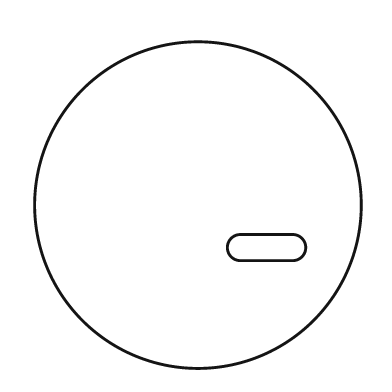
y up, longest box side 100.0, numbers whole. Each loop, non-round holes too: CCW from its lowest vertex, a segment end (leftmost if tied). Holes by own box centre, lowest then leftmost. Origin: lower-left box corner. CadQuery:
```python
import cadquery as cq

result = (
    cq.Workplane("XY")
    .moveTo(50.0, 50.0)
    .circle(50.0)
    .moveTo(63.0, 33.0)
    .lineTo(79.0, 33.0)
    .threePointArc((83.0, 37.0), (79.0, 41.0))
    .lineTo(63.0, 41.0)
    .threePointArc((59.0, 37.0), (63.0, 33.0))
    .close()
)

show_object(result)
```